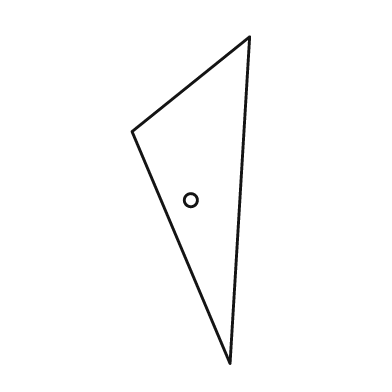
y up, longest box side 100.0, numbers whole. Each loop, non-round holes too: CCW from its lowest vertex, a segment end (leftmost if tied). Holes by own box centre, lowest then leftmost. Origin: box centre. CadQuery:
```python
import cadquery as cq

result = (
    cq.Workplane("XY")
    .moveTo(12.0, -50.0)
    .lineTo(18.0, 50.0)
    .lineTo(-18.0, 21.0)
    .close()
    .moveTo(0.0, 0.0)
    .circle(2.0)
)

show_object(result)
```